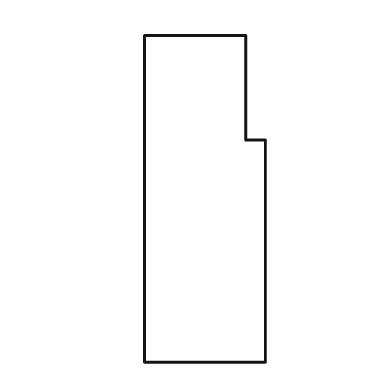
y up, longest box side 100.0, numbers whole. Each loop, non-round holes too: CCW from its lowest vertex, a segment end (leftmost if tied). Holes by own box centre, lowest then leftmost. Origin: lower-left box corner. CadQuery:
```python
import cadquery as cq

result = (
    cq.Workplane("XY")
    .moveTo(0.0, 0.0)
    .lineTo(37.0, 0.0)
    .lineTo(37.0, 68.0)
    .lineTo(31.0, 68.0)
    .lineTo(31.0, 100.0)
    .lineTo(0.0, 100.0)
    .close()
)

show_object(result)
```